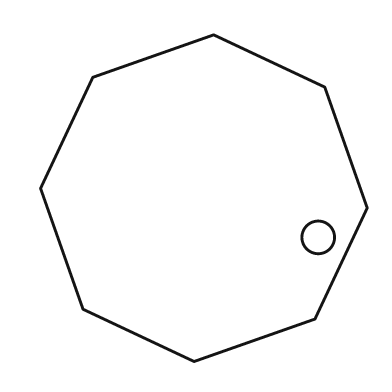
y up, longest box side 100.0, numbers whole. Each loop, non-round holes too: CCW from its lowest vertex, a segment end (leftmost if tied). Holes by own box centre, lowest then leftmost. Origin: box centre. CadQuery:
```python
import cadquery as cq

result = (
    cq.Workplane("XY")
    .moveTo(-3.0, -50.0)
    .lineTo(34.0, -37.0)
    .lineTo(50.0, -3.0)
    .lineTo(37.0, 34.0)
    .lineTo(3.0, 50.0)
    .lineTo(-34.0, 37.0)
    .lineTo(-50.0, 3.0)
    .lineTo(-37.0, -34.0)
    .close()
    .moveTo(35.0, -12.0)
    .circle(5.0)
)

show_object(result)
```